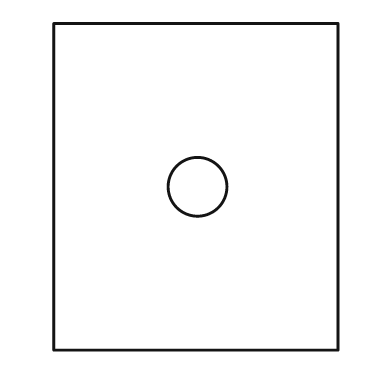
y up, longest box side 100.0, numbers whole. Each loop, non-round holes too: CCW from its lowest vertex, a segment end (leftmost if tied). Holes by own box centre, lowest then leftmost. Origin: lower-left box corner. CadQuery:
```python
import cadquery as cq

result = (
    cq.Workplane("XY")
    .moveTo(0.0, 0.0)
    .lineTo(87.0, 0.0)
    .lineTo(87.0, 100.0)
    .lineTo(0.0, 100.0)
    .close()
    .moveTo(44.0, 50.0)
    .circle(9.0)
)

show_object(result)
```